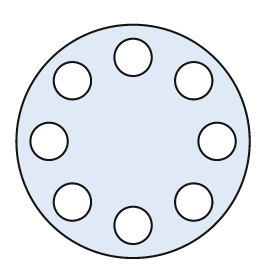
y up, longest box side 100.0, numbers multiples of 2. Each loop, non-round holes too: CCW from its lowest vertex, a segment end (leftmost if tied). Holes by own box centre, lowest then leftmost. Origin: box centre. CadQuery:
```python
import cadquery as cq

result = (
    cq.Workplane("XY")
    .moveTo(0.0, 0.0)
    .circle(50.0)
    .moveTo(0.0, -36.0)
    .circle(8.0)
    .moveTo(-26.0, -26.0)
    .circle(8.0)
    .moveTo(26.0, -26.0)
    .circle(8.0)
    .moveTo(-36.0, 0.0)
    .circle(8.0)
    .moveTo(36.0, 0.0)
    .circle(8.0)
    .moveTo(-26.0, 26.0)
    .circle(8.0)
    .moveTo(26.0, 26.0)
    .circle(8.0)
    .moveTo(0.0, 36.0)
    .circle(8.0)
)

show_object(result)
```